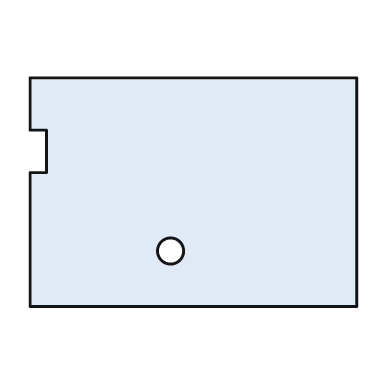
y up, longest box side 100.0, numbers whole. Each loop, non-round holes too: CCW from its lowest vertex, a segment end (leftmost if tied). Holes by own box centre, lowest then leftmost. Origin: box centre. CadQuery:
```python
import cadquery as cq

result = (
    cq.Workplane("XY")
    .moveTo(-50.0, -35.0)
    .lineTo(50.0, -35.0)
    .lineTo(50.0, 35.0)
    .lineTo(-50.0, 35.0)
    .lineTo(-50.0, 19.0)
    .lineTo(-45.0, 19.0)
    .lineTo(-45.0, 6.0)
    .lineTo(-50.0, 6.0)
    .close()
    .moveTo(-7.0, -18.0)
    .circle(4.0)
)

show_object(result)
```